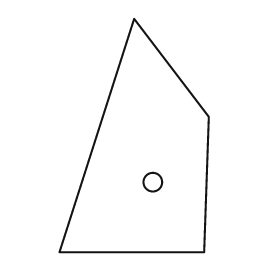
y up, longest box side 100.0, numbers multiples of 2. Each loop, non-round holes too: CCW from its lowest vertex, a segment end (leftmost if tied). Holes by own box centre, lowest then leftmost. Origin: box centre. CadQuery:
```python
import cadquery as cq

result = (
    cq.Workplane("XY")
    .moveTo(-32.0, -50.0)
    .lineTo(30.0, -50.0)
    .lineTo(32.0, 8.0)
    .lineTo(0.0, 50.0)
    .close()
    .moveTo(8.0, -20.0)
    .circle(4.0)
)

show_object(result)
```